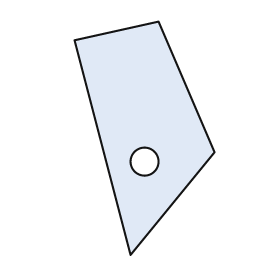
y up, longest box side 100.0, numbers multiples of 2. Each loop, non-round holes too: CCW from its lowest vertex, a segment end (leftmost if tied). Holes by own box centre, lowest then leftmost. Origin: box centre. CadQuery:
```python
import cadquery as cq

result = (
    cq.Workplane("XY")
    .moveTo(-6.0, -50.0)
    .lineTo(30.0, -6.0)
    .lineTo(6.0, 50.0)
    .lineTo(-30.0, 42.0)
    .close()
    .moveTo(0.0, -10.0)
    .circle(6.0)
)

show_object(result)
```